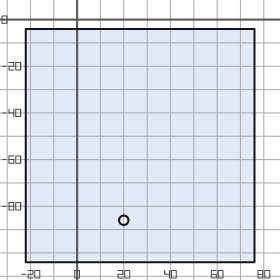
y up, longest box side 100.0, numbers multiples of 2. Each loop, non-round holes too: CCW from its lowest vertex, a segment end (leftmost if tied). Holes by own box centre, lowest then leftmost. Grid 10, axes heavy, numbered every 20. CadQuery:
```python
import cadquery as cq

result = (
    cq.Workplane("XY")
    .moveTo(-22.0, -104.0)
    .lineTo(76.0, -104.0)
    .lineTo(76.0, -4.0)
    .lineTo(-22.0, -4.0)
    .close()
    .moveTo(20.0, -86.0)
    .circle(2.0)
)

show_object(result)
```